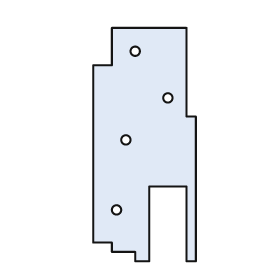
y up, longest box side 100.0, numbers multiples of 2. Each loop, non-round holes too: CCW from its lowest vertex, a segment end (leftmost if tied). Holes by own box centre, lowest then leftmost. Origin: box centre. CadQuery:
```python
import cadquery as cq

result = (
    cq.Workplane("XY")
    .moveTo(-4.0, -50.0)
    .lineTo(2.0, -50.0)
    .lineTo(2.0, -18.0)
    .lineTo(18.0, -18.0)
    .lineTo(18.0, -50.0)
    .lineTo(22.0, -50.0)
    .lineTo(22.0, 12.0)
    .lineTo(18.0, 12.0)
    .lineTo(18.0, 50.0)
    .lineTo(-14.0, 50.0)
    .lineTo(-14.0, 34.0)
    .lineTo(-22.0, 34.0)
    .lineTo(-22.0, -42.0)
    .lineTo(-14.0, -42.0)
    .lineTo(-14.0, -46.0)
    .lineTo(-4.0, -46.0)
    .close()
    .moveTo(-12.0, -28.0)
    .circle(2.0)
    .moveTo(-8.0, 2.0)
    .circle(2.0)
    .moveTo(10.0, 20.0)
    .circle(2.0)
    .moveTo(-4.0, 40.0)
    .circle(2.0)
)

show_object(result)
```